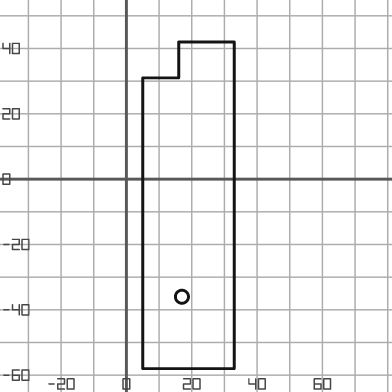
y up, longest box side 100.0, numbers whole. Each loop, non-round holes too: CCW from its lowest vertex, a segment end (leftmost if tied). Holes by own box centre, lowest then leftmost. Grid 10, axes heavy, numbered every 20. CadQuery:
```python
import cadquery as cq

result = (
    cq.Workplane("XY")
    .moveTo(5.0, -58.0)
    .lineTo(33.0, -58.0)
    .lineTo(33.0, 42.0)
    .lineTo(16.0, 42.0)
    .lineTo(16.0, 31.0)
    .lineTo(5.0, 31.0)
    .close()
    .moveTo(17.0, -36.0)
    .circle(2.0)
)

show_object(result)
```